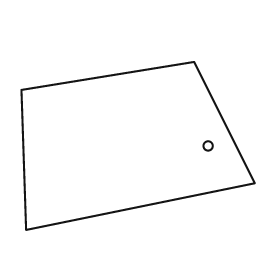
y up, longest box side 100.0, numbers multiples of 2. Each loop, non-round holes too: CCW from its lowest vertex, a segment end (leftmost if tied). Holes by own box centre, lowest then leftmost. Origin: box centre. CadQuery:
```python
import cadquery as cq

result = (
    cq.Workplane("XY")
    .moveTo(-48.0, -36.0)
    .lineTo(50.0, -16.0)
    .lineTo(24.0, 36.0)
    .lineTo(-50.0, 24.0)
    .close()
    .moveTo(30.0, 0.0)
    .circle(2.0)
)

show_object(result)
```